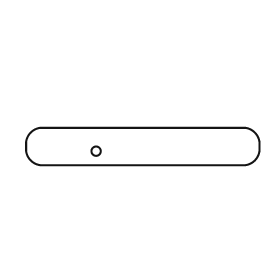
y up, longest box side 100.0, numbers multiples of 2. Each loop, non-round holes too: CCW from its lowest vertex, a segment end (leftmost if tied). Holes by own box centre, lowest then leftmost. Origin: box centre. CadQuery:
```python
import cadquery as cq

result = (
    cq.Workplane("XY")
    .moveTo(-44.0, -8.0)
    .lineTo(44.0, -8.0)
    .threePointArc((48.0, -6.0), (50.0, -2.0))
    .lineTo(50.0, 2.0)
    .threePointArc((48.0, 6.0), (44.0, 8.0))
    .lineTo(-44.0, 8.0)
    .threePointArc((-48.0, 6.0), (-50.0, 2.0))
    .lineTo(-50.0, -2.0)
    .threePointArc((-48.0, -6.0), (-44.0, -8.0))
    .close()
    .moveTo(-20.0, -2.0)
    .circle(2.0)
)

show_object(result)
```